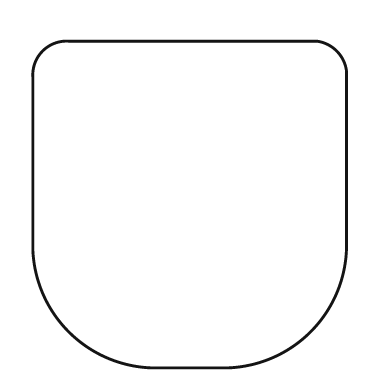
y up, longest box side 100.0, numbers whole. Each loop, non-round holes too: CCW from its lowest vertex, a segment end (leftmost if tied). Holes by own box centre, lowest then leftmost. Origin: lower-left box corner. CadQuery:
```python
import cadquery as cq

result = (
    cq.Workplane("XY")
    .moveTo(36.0, 0.0)
    .lineTo(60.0, 0.0)
    .threePointArc((85.0, 11.0), (96.0, 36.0))
    .lineTo(96.0, 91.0)
    .threePointArc((93.0, 97.0), (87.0, 100.0))
    .lineTo(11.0, 100.0)
    .threePointArc((3.0, 97.0), (0.0, 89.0))
    .lineTo(0.0, 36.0)
    .threePointArc((11.0, 11.0), (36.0, 0.0))
    .close()
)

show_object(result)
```